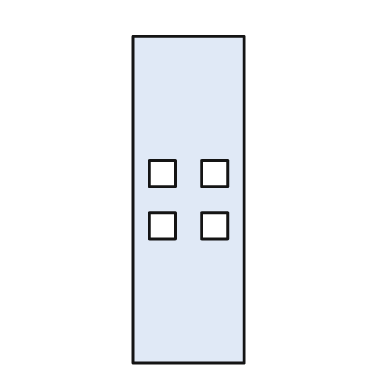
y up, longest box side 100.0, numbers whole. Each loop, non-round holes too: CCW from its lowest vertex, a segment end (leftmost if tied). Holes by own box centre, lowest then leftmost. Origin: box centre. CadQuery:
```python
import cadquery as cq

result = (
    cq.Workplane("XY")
    .moveTo(-17.0, -50.0)
    .lineTo(17.0, -50.0)
    .lineTo(17.0, 50.0)
    .lineTo(-17.0, 50.0)
    .close()
    .moveTo(-12.0, -12.0)
    .lineTo(-4.0, -12.0)
    .lineTo(-4.0, -4.0)
    .lineTo(-12.0, -4.0)
    .close()
    .moveTo(4.0, -12.0)
    .lineTo(12.0, -12.0)
    .lineTo(12.0, -4.0)
    .lineTo(4.0, -4.0)
    .close()
    .moveTo(-12.0, 4.0)
    .lineTo(-4.0, 4.0)
    .lineTo(-4.0, 12.0)
    .lineTo(-12.0, 12.0)
    .close()
    .moveTo(4.0, 4.0)
    .lineTo(12.0, 4.0)
    .lineTo(12.0, 12.0)
    .lineTo(4.0, 12.0)
    .close()
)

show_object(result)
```